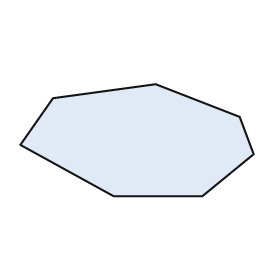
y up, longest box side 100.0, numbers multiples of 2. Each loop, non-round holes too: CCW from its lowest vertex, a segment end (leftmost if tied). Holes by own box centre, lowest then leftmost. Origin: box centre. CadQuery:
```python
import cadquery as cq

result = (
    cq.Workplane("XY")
    .moveTo(-10.0, -24.0)
    .lineTo(28.0, -24.0)
    .lineTo(50.0, -6.0)
    .lineTo(44.0, 10.0)
    .lineTo(8.0, 24.0)
    .lineTo(-36.0, 18.0)
    .lineTo(-50.0, -2.0)
    .close()
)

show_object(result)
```